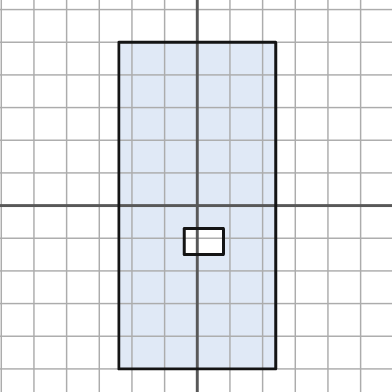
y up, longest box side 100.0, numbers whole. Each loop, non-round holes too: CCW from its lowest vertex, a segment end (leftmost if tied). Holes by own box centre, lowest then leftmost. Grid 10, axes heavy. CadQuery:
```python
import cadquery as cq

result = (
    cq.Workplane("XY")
    .moveTo(-24.0, -50.0)
    .lineTo(24.0, -50.0)
    .lineTo(24.0, 50.0)
    .lineTo(-24.0, 50.0)
    .close()
    .moveTo(-4.0, -15.0)
    .lineTo(8.0, -15.0)
    .lineTo(8.0, -7.0)
    .lineTo(-4.0, -7.0)
    .close()
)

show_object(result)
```